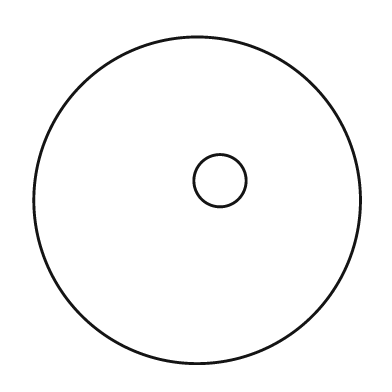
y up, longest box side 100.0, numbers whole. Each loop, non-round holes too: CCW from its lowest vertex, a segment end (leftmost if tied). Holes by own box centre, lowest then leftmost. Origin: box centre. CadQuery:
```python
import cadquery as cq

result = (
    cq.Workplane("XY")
    .moveTo(0.0, 0.0)
    .circle(50.0)
    .moveTo(7.0, 6.0)
    .circle(8.0)
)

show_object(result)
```